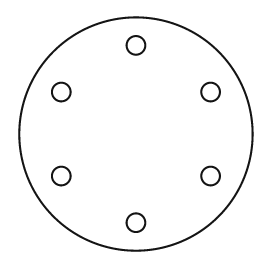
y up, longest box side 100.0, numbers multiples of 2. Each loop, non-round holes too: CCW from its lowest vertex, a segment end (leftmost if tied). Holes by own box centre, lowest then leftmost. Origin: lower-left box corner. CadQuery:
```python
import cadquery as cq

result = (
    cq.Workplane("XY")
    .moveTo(50.0, 50.0)
    .circle(50.0)
    .moveTo(50.0, 12.0)
    .circle(4.0)
    .moveTo(18.0, 32.0)
    .circle(4.0)
    .moveTo(82.0, 32.0)
    .circle(4.0)
    .moveTo(18.0, 68.0)
    .circle(4.0)
    .moveTo(82.0, 68.0)
    .circle(4.0)
    .moveTo(50.0, 88.0)
    .circle(4.0)
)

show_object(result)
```